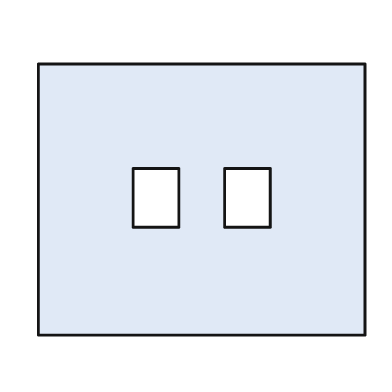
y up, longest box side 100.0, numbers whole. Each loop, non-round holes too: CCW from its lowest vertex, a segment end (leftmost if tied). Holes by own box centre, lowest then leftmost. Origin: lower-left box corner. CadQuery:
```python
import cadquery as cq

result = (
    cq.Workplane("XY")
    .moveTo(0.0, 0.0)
    .lineTo(100.0, 0.0)
    .lineTo(100.0, 83.0)
    .lineTo(0.0, 83.0)
    .close()
    .moveTo(29.0, 33.0)
    .lineTo(43.0, 33.0)
    .lineTo(43.0, 51.0)
    .lineTo(29.0, 51.0)
    .close()
    .moveTo(57.0, 33.0)
    .lineTo(71.0, 33.0)
    .lineTo(71.0, 51.0)
    .lineTo(57.0, 51.0)
    .close()
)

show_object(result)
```